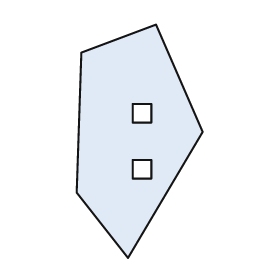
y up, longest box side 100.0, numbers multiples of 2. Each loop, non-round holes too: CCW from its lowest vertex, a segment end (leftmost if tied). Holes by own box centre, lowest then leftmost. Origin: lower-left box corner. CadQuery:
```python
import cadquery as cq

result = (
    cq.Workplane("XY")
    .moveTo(22.0, 0.0)
    .lineTo(54.0, 54.0)
    .lineTo(34.0, 100.0)
    .lineTo(2.0, 88.0)
    .lineTo(0.0, 28.0)
    .close()
    .moveTo(24.0, 34.0)
    .lineTo(32.0, 34.0)
    .lineTo(32.0, 42.0)
    .lineTo(24.0, 42.0)
    .close()
    .moveTo(24.0, 58.0)
    .lineTo(32.0, 58.0)
    .lineTo(32.0, 66.0)
    .lineTo(24.0, 66.0)
    .close()
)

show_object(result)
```